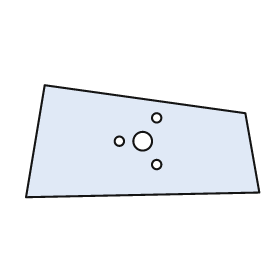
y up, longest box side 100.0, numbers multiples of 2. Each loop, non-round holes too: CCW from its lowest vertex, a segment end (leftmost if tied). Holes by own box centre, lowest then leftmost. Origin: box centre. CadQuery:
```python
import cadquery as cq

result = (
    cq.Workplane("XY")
    .moveTo(-50.0, -24.0)
    .lineTo(50.0, -22.0)
    .lineTo(44.0, 12.0)
    .lineTo(-42.0, 24.0)
    .close()
    .moveTo(6.0, -10.0)
    .circle(2.0)
    .moveTo(-10.0, 0.0)
    .circle(2.0)
    .moveTo(0.0, 0.0)
    .circle(4.0)
    .moveTo(6.0, 10.0)
    .circle(2.0)
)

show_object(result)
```